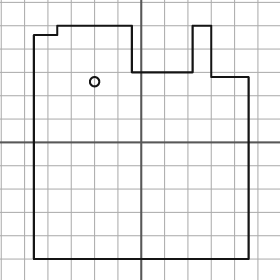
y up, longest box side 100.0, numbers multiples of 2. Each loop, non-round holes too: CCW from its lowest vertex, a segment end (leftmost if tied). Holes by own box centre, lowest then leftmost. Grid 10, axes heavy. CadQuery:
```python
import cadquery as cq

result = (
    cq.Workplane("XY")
    .moveTo(-46.0, -50.0)
    .lineTo(46.0, -50.0)
    .lineTo(46.0, 28.0)
    .lineTo(30.0, 28.0)
    .lineTo(30.0, 50.0)
    .lineTo(22.0, 50.0)
    .lineTo(22.0, 30.0)
    .lineTo(-4.0, 30.0)
    .lineTo(-4.0, 50.0)
    .lineTo(-36.0, 50.0)
    .lineTo(-36.0, 46.0)
    .lineTo(-46.0, 46.0)
    .close()
    .moveTo(-20.0, 26.0)
    .circle(2.0)
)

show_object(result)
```